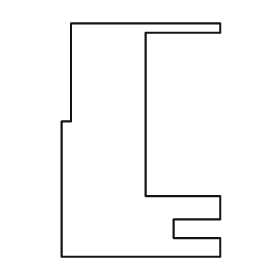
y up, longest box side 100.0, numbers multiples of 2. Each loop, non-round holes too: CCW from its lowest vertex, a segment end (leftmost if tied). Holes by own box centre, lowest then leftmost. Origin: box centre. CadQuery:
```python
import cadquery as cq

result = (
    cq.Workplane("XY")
    .moveTo(-34.0, -50.0)
    .lineTo(34.0, -50.0)
    .lineTo(34.0, -42.0)
    .lineTo(14.0, -42.0)
    .lineTo(14.0, -34.0)
    .lineTo(34.0, -34.0)
    .lineTo(34.0, -24.0)
    .lineTo(2.0, -24.0)
    .lineTo(2.0, 46.0)
    .lineTo(34.0, 46.0)
    .lineTo(34.0, 50.0)
    .lineTo(-30.0, 50.0)
    .lineTo(-30.0, 8.0)
    .lineTo(-34.0, 8.0)
    .close()
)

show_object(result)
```